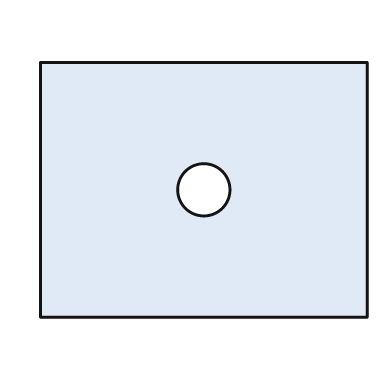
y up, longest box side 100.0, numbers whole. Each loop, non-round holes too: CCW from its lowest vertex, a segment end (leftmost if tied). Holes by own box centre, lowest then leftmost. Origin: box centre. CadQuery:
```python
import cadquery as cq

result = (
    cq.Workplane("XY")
    .moveTo(-50.0, -39.0)
    .lineTo(50.0, -39.0)
    .lineTo(50.0, 39.0)
    .lineTo(-50.0, 39.0)
    .close()
    .moveTo(0.0, 0.0)
    .circle(8.0)
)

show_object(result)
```